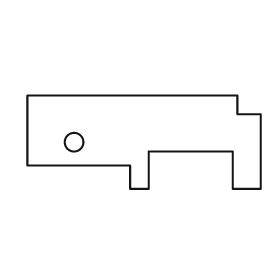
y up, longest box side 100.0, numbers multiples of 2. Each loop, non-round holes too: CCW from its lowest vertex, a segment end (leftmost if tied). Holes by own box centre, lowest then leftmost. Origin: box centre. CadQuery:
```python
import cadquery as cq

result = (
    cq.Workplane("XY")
    .moveTo(-6.0, -20.0)
    .lineTo(2.0, -20.0)
    .lineTo(2.0, -4.0)
    .lineTo(38.0, -4.0)
    .lineTo(38.0, -20.0)
    .lineTo(50.0, -20.0)
    .lineTo(50.0, 12.0)
    .lineTo(40.0, 12.0)
    .lineTo(40.0, 20.0)
    .lineTo(-50.0, 20.0)
    .lineTo(-50.0, -10.0)
    .lineTo(-6.0, -10.0)
    .close()
    .moveTo(-30.0, 0.0)
    .circle(4.0)
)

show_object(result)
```